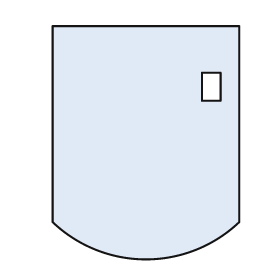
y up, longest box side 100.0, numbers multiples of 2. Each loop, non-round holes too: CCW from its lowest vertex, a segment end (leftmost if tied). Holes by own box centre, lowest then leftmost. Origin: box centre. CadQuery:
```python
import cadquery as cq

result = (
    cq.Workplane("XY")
    .moveTo(-40.0, -34.0)
    .threePointArc((0.0, -50.0), (40.0, -34.0))
    .lineTo(40.0, 50.0)
    .lineTo(-40.0, 50.0)
    .close()
    .moveTo(24.0, 18.0)
    .lineTo(32.0, 18.0)
    .lineTo(32.0, 30.0)
    .lineTo(24.0, 30.0)
    .close()
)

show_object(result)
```